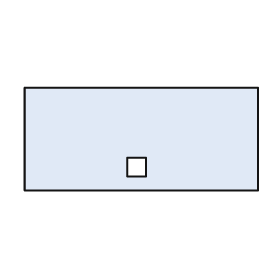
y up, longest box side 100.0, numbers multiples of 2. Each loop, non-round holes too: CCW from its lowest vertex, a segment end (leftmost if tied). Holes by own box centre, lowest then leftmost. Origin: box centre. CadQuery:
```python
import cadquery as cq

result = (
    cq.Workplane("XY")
    .moveTo(-50.0, -22.0)
    .lineTo(50.0, -22.0)
    .lineTo(50.0, 22.0)
    .lineTo(-50.0, 22.0)
    .close()
    .moveTo(-6.0, -16.0)
    .lineTo(2.0, -16.0)
    .lineTo(2.0, -8.0)
    .lineTo(-6.0, -8.0)
    .close()
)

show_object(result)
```